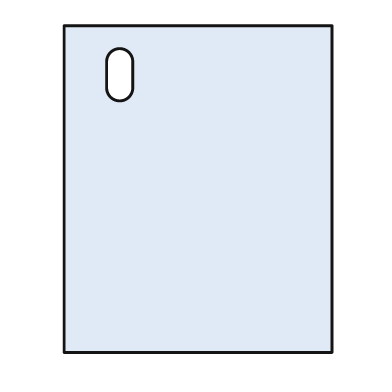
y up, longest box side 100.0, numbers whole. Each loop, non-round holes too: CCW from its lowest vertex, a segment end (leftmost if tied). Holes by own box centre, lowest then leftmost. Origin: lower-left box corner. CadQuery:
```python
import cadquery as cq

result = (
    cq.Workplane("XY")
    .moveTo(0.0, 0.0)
    .lineTo(82.0, 0.0)
    .lineTo(82.0, 100.0)
    .lineTo(0.0, 100.0)
    .close()
    .moveTo(13.0, 81.0)
    .threePointArc((17.0, 77.0), (21.0, 81.0))
    .lineTo(21.0, 89.0)
    .threePointArc((17.0, 93.0), (13.0, 89.0))
    .close()
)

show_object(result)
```